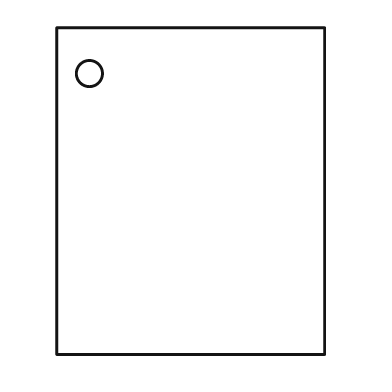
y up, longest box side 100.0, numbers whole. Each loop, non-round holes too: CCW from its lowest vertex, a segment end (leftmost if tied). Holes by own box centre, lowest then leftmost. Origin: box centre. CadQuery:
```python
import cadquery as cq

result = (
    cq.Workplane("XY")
    .moveTo(-41.0, -50.0)
    .lineTo(41.0, -50.0)
    .lineTo(41.0, 50.0)
    .lineTo(-41.0, 50.0)
    .close()
    .moveTo(-31.0, 36.0)
    .circle(4.0)
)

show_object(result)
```